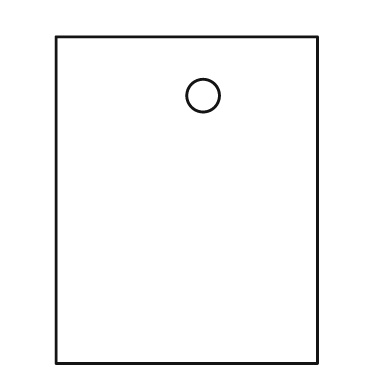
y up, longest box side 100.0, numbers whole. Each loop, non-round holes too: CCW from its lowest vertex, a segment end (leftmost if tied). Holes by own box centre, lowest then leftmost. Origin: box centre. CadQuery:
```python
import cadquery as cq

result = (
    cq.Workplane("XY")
    .moveTo(-40.0, -50.0)
    .lineTo(40.0, -50.0)
    .lineTo(40.0, 50.0)
    .lineTo(-40.0, 50.0)
    .close()
    .moveTo(5.0, 32.0)
    .circle(5.0)
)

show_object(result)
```